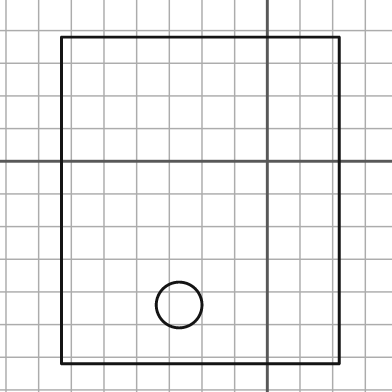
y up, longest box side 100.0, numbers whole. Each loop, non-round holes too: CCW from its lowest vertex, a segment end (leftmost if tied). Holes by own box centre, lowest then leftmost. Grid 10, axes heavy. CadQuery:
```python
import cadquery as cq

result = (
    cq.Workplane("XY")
    .moveTo(-63.0, -62.0)
    .lineTo(22.0, -62.0)
    .lineTo(22.0, 38.0)
    .lineTo(-63.0, 38.0)
    .close()
    .moveTo(-27.0, -44.0)
    .circle(7.0)
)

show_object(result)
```